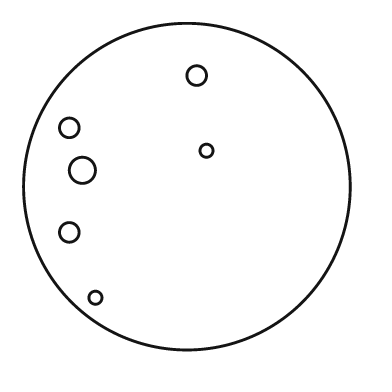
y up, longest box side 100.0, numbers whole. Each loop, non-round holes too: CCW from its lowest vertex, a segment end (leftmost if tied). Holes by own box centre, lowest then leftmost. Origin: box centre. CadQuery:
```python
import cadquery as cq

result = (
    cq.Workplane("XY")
    .moveTo(0.0, 0.0)
    .circle(50.0)
    .moveTo(-28.0, -34.0)
    .circle(2.0)
    .moveTo(-36.0, -14.0)
    .circle(3.0)
    .moveTo(-32.0, 5.0)
    .circle(4.0)
    .moveTo(6.0, 11.0)
    .circle(2.0)
    .moveTo(-36.0, 18.0)
    .circle(3.0)
    .moveTo(3.0, 34.0)
    .circle(3.0)
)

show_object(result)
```